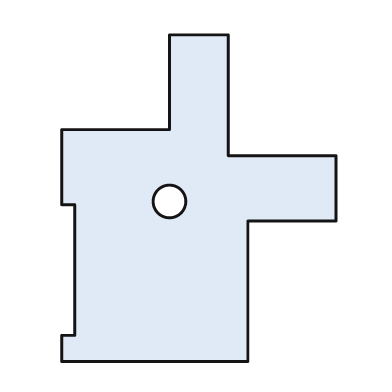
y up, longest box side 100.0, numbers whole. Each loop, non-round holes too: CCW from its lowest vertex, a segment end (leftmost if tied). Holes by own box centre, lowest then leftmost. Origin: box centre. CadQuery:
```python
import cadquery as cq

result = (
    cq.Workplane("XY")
    .moveTo(-42.0, -50.0)
    .lineTo(15.0, -50.0)
    .lineTo(15.0, -7.0)
    .lineTo(42.0, -7.0)
    .lineTo(42.0, 13.0)
    .lineTo(9.0, 13.0)
    .lineTo(9.0, 50.0)
    .lineTo(-9.0, 50.0)
    .lineTo(-9.0, 21.0)
    .lineTo(-42.0, 21.0)
    .lineTo(-42.0, -2.0)
    .lineTo(-38.0, -2.0)
    .lineTo(-38.0, -42.0)
    .lineTo(-42.0, -42.0)
    .close()
    .moveTo(-9.0, -1.0)
    .circle(5.0)
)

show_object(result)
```